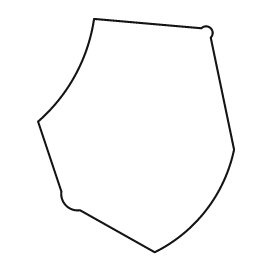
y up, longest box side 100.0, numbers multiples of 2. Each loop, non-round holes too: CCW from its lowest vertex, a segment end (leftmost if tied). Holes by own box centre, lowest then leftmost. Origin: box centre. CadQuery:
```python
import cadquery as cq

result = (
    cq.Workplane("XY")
    .moveTo(8.0, -50.0)
    .threePointArc((30.0, -32.0), (42.0, -6.0))
    .lineTo(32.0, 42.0)
    .threePointArc((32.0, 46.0), (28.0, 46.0))
    .lineTo(-18.0, 50.0)
    .threePointArc((-26.0, 26.0), (-42.0, 6.0))
    .lineTo(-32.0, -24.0)
    .threePointArc((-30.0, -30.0), (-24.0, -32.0))
    .close()
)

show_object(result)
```